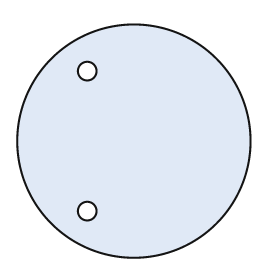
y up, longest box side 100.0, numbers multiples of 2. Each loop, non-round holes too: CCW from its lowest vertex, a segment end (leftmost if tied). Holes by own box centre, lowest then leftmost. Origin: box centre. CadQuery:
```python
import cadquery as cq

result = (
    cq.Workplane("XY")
    .moveTo(0.0, 0.0)
    .circle(50.0)
    .moveTo(-20.0, -30.0)
    .circle(4.0)
    .moveTo(-20.0, 30.0)
    .circle(4.0)
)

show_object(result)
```